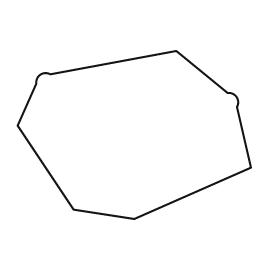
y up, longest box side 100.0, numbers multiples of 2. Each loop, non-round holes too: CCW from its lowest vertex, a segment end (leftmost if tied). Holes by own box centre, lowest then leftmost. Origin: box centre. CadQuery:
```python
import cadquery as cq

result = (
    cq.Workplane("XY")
    .moveTo(0.0, -36.0)
    .lineTo(50.0, -14.0)
    .lineTo(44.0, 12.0)
    .threePointArc((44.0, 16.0), (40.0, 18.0))
    .lineTo(18.0, 36.0)
    .lineTo(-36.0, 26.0)
    .threePointArc((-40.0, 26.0), (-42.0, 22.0))
    .lineTo(-50.0, 4.0)
    .lineTo(-26.0, -32.0)
    .close()
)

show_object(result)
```